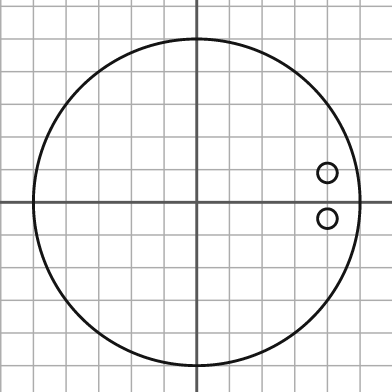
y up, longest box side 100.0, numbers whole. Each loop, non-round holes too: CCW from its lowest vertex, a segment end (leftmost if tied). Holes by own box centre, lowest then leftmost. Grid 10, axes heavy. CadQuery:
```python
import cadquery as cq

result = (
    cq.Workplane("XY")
    .moveTo(0.0, 0.0)
    .circle(50.0)
    .moveTo(40.0, -5.0)
    .circle(3.0)
    .moveTo(40.0, 9.0)
    .circle(3.0)
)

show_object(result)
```